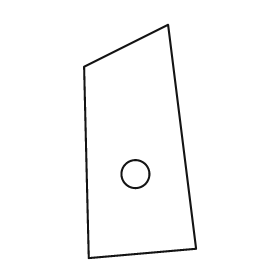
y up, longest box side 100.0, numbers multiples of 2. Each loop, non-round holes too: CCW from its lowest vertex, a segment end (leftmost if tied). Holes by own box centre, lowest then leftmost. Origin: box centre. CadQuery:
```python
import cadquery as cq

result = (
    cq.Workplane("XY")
    .moveTo(-22.0, -50.0)
    .lineTo(24.0, -46.0)
    .lineTo(12.0, 50.0)
    .lineTo(-24.0, 32.0)
    .close()
    .moveTo(-2.0, -14.0)
    .circle(6.0)
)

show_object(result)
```